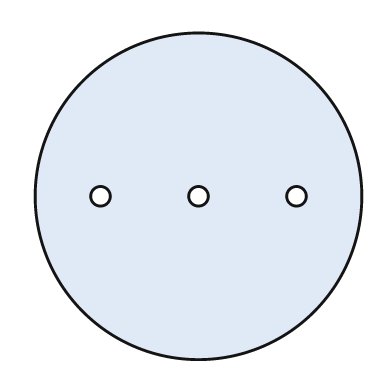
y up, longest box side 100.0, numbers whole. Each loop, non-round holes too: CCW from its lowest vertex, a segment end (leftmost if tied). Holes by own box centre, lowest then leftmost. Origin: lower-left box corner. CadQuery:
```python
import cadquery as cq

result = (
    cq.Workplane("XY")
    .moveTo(50.0, 50.0)
    .circle(50.0)
    .moveTo(20.0, 50.0)
    .circle(3.0)
    .moveTo(50.0, 50.0)
    .circle(3.0)
    .moveTo(80.0, 50.0)
    .circle(3.0)
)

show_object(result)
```